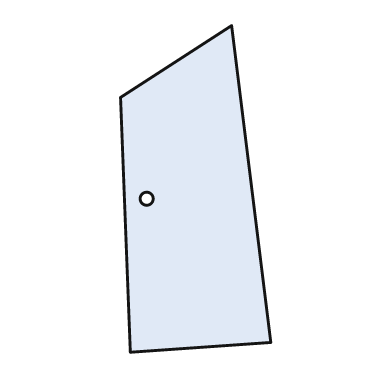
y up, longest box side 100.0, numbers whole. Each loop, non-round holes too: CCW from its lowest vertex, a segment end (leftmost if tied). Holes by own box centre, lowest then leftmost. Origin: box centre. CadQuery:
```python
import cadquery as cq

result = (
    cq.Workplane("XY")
    .moveTo(-20.0, -50.0)
    .lineTo(23.0, -47.0)
    .lineTo(11.0, 50.0)
    .lineTo(-23.0, 28.0)
    .close()
    .moveTo(-15.0, -3.0)
    .circle(2.0)
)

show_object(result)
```